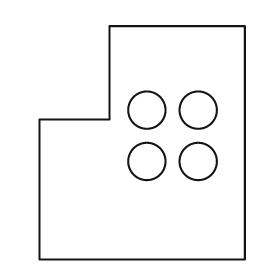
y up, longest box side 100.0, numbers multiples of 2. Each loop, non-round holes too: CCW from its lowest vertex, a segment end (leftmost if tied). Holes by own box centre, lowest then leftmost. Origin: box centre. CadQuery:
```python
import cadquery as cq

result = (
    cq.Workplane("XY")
    .moveTo(-44.0, -50.0)
    .lineTo(44.0, -50.0)
    .lineTo(44.0, 50.0)
    .lineTo(-14.0, 50.0)
    .lineTo(-14.0, 10.0)
    .lineTo(-44.0, 10.0)
    .close()
    .moveTo(2.0, -8.0)
    .circle(8.0)
    .moveTo(24.0, -8.0)
    .circle(8.0)
    .moveTo(2.0, 14.0)
    .circle(8.0)
    .moveTo(24.0, 14.0)
    .circle(8.0)
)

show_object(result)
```